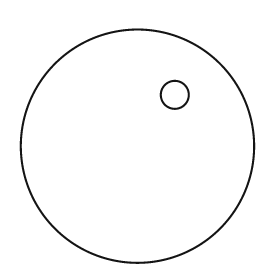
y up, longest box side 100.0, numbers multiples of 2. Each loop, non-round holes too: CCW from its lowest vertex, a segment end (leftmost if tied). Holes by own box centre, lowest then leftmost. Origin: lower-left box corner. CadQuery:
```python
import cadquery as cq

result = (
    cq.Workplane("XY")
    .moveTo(50.0, 50.0)
    .circle(50.0)
    .moveTo(66.0, 72.0)
    .circle(6.0)
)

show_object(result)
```